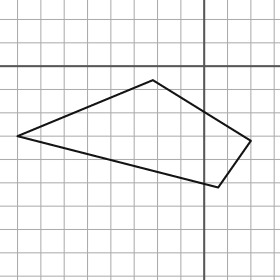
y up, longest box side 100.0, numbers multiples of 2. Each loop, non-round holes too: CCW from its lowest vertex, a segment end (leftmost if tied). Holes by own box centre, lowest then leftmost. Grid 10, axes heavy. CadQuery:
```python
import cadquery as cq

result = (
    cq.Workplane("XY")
    .moveTo(6.0, -52.0)
    .lineTo(20.0, -32.0)
    .lineTo(-22.0, -6.0)
    .lineTo(-80.0, -30.0)
    .close()
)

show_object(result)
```